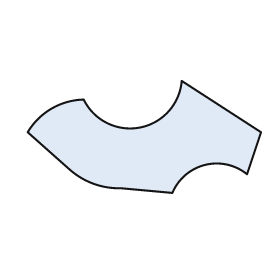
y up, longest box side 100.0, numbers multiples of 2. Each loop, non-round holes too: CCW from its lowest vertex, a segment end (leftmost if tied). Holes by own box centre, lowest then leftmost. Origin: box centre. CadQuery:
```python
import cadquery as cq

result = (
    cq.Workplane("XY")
    .moveTo(12.0, -24.0)
    .threePointArc((26.0, -12.0), (44.0, -16.0))
    .lineTo(50.0, 2.0)
    .lineTo(16.0, 24.0)
    .threePointArc((-2.0, 4.0), (-26.0, 16.0))
    .threePointArc((-40.0, 12.0), (-50.0, 2.0))
    .lineTo(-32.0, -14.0)
    .threePointArc((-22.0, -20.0), (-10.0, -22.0))
    .close()
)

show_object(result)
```